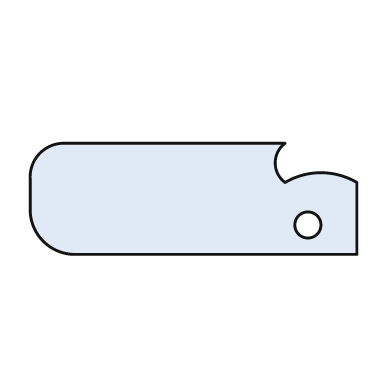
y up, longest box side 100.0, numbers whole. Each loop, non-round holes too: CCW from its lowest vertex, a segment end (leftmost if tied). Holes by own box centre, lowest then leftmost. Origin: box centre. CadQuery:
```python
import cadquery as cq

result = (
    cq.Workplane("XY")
    .moveTo(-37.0, -17.0)
    .lineTo(50.0, -17.0)
    .lineTo(50.0, 5.0)
    .threePointArc((39.0, 8.0), (28.0, 5.0))
    .threePointArc((25.0, 11.0), (28.0, 17.0))
    .lineTo(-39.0, 17.0)
    .threePointArc((-47.0, 14.0), (-50.0, 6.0))
    .lineTo(-50.0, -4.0)
    .threePointArc((-46.0, -13.0), (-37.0, -17.0))
    .close()
    .moveTo(35.0, -8.0)
    .circle(4.0)
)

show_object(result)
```